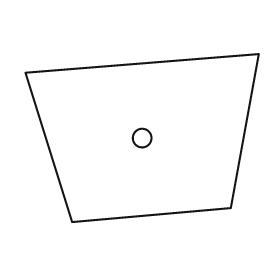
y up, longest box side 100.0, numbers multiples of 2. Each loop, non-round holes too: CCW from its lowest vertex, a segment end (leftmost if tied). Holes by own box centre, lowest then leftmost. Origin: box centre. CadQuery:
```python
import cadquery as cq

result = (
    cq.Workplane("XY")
    .moveTo(-30.0, -36.0)
    .lineTo(38.0, -30.0)
    .lineTo(50.0, 36.0)
    .lineTo(-50.0, 28.0)
    .close()
    .moveTo(0.0, 0.0)
    .circle(4.0)
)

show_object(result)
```